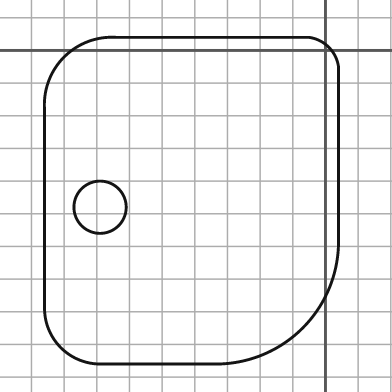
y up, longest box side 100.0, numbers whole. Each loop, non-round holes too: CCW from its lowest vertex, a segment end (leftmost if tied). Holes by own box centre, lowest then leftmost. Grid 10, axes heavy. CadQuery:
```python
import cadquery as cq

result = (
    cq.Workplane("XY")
    .moveTo(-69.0, -96.0)
    .lineTo(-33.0, -96.0)
    .threePointArc((-7.0, -85.0), (4.0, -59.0))
    .lineTo(4.0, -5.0)
    .threePointArc((1.0, 1.0), (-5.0, 4.0))
    .lineTo(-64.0, 4.0)
    .threePointArc((-80.0, -2.0), (-86.0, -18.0))
    .lineTo(-86.0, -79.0)
    .threePointArc((-81.0, -91.0), (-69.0, -96.0))
    .close()
    .moveTo(-69.0, -48.0)
    .circle(8.0)
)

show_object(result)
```